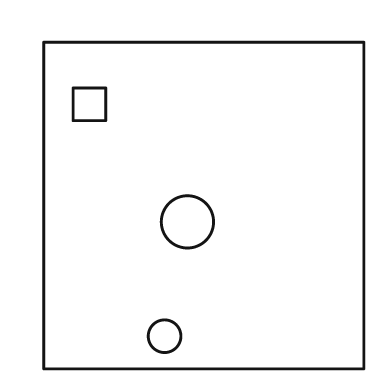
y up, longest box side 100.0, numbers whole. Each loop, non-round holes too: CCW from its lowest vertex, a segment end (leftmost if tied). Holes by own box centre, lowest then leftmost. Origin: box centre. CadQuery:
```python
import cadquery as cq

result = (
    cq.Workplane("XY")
    .moveTo(-49.0, -50.0)
    .lineTo(49.0, -50.0)
    .lineTo(49.0, 50.0)
    .lineTo(-49.0, 50.0)
    .close()
    .moveTo(-12.0, -40.0)
    .circle(5.0)
    .moveTo(-5.0, -5.0)
    .circle(8.0)
    .moveTo(-40.0, 26.0)
    .lineTo(-30.0, 26.0)
    .lineTo(-30.0, 36.0)
    .lineTo(-40.0, 36.0)
    .close()
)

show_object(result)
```